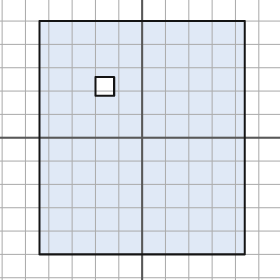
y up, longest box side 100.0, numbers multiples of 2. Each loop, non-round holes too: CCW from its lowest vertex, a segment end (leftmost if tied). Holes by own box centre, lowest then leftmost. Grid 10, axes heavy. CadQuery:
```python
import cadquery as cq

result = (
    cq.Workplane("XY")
    .moveTo(-44.0, -50.0)
    .lineTo(44.0, -50.0)
    .lineTo(44.0, 50.0)
    .lineTo(-44.0, 50.0)
    .close()
    .moveTo(-20.0, 18.0)
    .lineTo(-12.0, 18.0)
    .lineTo(-12.0, 26.0)
    .lineTo(-20.0, 26.0)
    .close()
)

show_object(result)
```